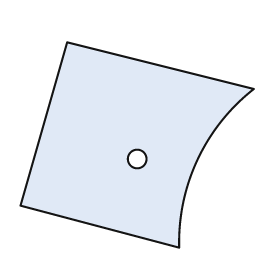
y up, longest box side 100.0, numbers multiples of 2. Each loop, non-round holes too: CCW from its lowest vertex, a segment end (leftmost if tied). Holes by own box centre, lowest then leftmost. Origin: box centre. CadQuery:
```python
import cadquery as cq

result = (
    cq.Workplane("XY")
    .moveTo(18.0, -44.0)
    .threePointArc((26.0, -6.0), (50.0, 24.0))
    .lineTo(-30.0, 44.0)
    .lineTo(-50.0, -26.0)
    .close()
    .moveTo(0.0, -6.0)
    .circle(4.0)
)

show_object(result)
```